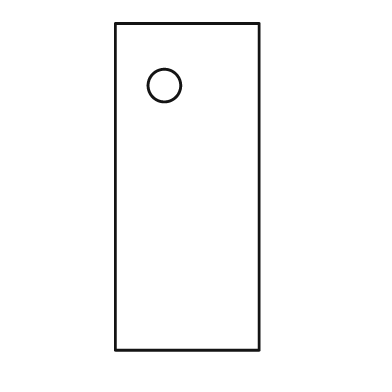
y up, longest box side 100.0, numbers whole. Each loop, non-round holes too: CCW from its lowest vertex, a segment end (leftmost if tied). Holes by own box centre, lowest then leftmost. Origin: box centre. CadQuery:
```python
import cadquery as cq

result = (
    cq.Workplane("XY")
    .moveTo(-22.0, -50.0)
    .lineTo(22.0, -50.0)
    .lineTo(22.0, 50.0)
    .lineTo(-22.0, 50.0)
    .close()
    .moveTo(-7.0, 31.0)
    .circle(5.0)
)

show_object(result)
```